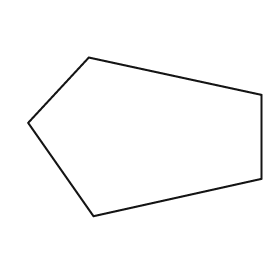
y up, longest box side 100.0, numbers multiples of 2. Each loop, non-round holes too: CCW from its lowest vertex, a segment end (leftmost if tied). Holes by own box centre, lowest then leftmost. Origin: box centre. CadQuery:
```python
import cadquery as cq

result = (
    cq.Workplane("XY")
    .moveTo(-22.0, -34.0)
    .lineTo(50.0, -18.0)
    .lineTo(50.0, 18.0)
    .lineTo(-24.0, 34.0)
    .lineTo(-50.0, 6.0)
    .close()
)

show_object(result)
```